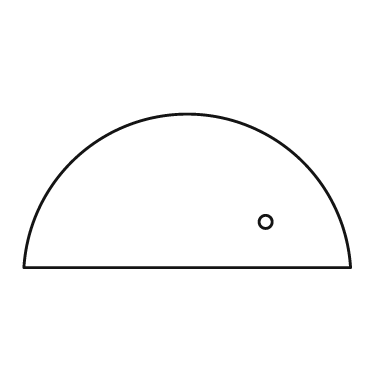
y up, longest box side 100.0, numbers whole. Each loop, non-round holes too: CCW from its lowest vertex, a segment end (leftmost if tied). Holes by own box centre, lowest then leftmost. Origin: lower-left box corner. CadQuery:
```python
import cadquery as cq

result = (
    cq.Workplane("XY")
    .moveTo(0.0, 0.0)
    .lineTo(100.0, 0.0)
    .threePointArc((50.0, 47.0), (0.0, 0.0))
    .close()
    .moveTo(74.0, 14.0)
    .circle(2.0)
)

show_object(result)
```